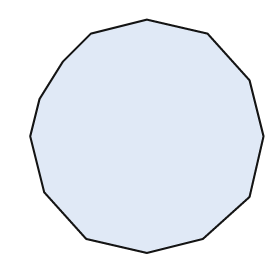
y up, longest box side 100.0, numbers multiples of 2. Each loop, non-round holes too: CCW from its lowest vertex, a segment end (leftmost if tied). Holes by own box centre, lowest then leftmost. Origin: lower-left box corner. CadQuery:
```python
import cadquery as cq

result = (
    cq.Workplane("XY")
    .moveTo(50.0, 0.0)
    .lineTo(74.0, 6.0)
    .lineTo(94.0, 24.0)
    .lineTo(100.0, 50.0)
    .lineTo(94.0, 74.0)
    .lineTo(76.0, 94.0)
    .lineTo(50.0, 100.0)
    .lineTo(26.0, 94.0)
    .lineTo(14.0, 82.0)
    .lineTo(4.0, 66.0)
    .lineTo(0.0, 50.0)
    .lineTo(6.0, 26.0)
    .lineTo(24.0, 6.0)
    .close()
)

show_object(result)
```